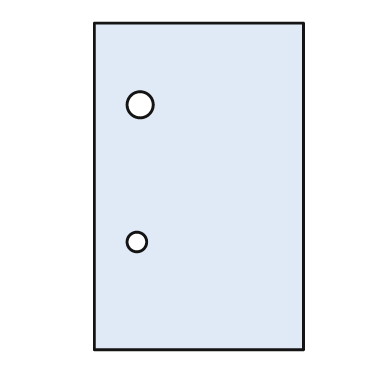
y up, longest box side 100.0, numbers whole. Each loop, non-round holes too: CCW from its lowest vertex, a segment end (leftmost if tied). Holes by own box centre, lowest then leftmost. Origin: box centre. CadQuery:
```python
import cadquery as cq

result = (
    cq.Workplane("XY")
    .moveTo(-32.0, -50.0)
    .lineTo(32.0, -50.0)
    .lineTo(32.0, 50.0)
    .lineTo(-32.0, 50.0)
    .close()
    .moveTo(-19.0, -17.0)
    .circle(3.0)
    .moveTo(-18.0, 25.0)
    .circle(4.0)
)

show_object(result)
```